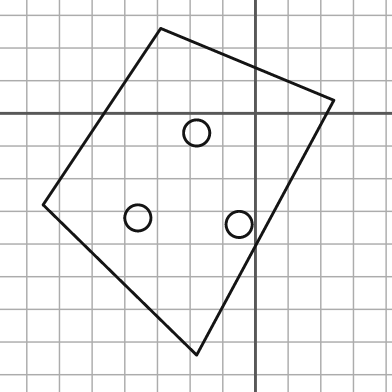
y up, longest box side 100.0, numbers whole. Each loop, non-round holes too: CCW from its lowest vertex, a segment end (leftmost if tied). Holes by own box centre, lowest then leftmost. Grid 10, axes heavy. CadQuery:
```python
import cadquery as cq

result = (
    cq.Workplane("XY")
    .moveTo(-18.0, -74.0)
    .lineTo(24.0, 4.0)
    .lineTo(-29.0, 26.0)
    .lineTo(-65.0, -28.0)
    .close()
    .moveTo(-5.0, -34.0)
    .circle(4.0)
    .moveTo(-36.0, -32.0)
    .circle(4.0)
    .moveTo(-18.0, -6.0)
    .circle(4.0)
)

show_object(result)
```